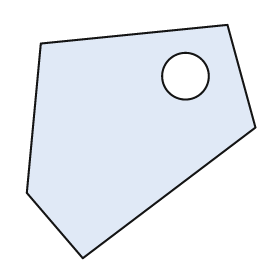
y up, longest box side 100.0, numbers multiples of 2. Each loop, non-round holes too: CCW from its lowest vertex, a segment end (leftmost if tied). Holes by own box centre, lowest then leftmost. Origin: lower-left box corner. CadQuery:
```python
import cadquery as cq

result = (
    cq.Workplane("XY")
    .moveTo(24.0, 0.0)
    .lineTo(98.0, 56.0)
    .lineTo(86.0, 100.0)
    .lineTo(6.0, 92.0)
    .lineTo(0.0, 28.0)
    .close()
    .moveTo(68.0, 78.0)
    .circle(10.0)
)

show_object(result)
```